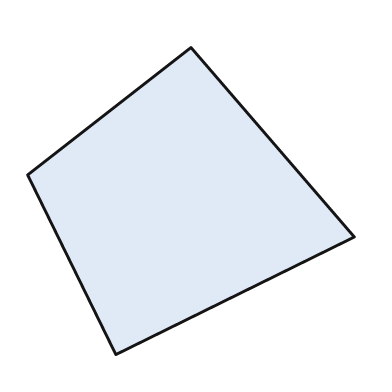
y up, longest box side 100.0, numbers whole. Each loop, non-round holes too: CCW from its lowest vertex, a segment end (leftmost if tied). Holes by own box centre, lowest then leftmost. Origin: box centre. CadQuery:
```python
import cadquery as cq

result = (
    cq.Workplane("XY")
    .moveTo(-23.0, -47.0)
    .lineTo(50.0, -11.0)
    .lineTo(0.0, 47.0)
    .lineTo(-50.0, 8.0)
    .close()
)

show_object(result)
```